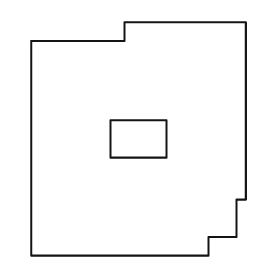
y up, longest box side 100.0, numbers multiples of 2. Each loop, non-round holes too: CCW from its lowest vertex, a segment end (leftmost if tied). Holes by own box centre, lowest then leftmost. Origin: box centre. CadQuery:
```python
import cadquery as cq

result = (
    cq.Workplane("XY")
    .moveTo(-46.0, -50.0)
    .lineTo(30.0, -50.0)
    .lineTo(30.0, -42.0)
    .lineTo(42.0, -42.0)
    .lineTo(42.0, -26.0)
    .lineTo(46.0, -26.0)
    .lineTo(46.0, 50.0)
    .lineTo(-6.0, 50.0)
    .lineTo(-6.0, 42.0)
    .lineTo(-46.0, 42.0)
    .close()
    .moveTo(-12.0, -8.0)
    .lineTo(12.0, -8.0)
    .lineTo(12.0, 8.0)
    .lineTo(-12.0, 8.0)
    .close()
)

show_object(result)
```